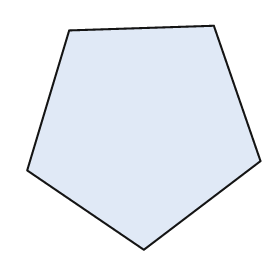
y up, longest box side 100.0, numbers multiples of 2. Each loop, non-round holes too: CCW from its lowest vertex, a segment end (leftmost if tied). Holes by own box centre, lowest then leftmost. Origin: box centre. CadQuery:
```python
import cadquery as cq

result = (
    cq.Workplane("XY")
    .moveTo(0.0, -48.0)
    .lineTo(50.0, -10.0)
    .lineTo(30.0, 48.0)
    .lineTo(-32.0, 46.0)
    .lineTo(-50.0, -14.0)
    .close()
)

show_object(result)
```